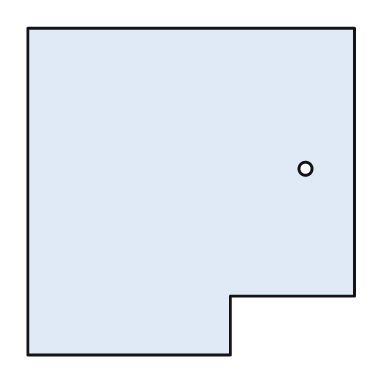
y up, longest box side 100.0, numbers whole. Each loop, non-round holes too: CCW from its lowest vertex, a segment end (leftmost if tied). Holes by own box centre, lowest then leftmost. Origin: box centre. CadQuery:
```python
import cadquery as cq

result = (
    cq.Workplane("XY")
    .moveTo(-50.0, -50.0)
    .lineTo(12.0, -50.0)
    .lineTo(12.0, -32.0)
    .lineTo(50.0, -32.0)
    .lineTo(50.0, 50.0)
    .lineTo(-50.0, 50.0)
    .close()
    .moveTo(35.0, 7.0)
    .circle(2.0)
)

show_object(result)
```